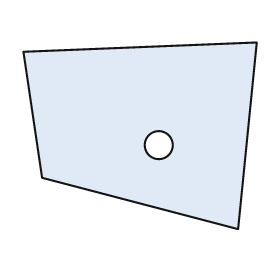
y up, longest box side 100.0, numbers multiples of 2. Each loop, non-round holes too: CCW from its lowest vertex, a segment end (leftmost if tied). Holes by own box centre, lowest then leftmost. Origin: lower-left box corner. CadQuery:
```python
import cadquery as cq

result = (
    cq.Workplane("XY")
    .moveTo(92.0, 0.0)
    .lineTo(100.0, 80.0)
    .lineTo(0.0, 76.0)
    .lineTo(8.0, 22.0)
    .close()
    .moveTo(58.0, 36.0)
    .circle(6.0)
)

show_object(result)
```